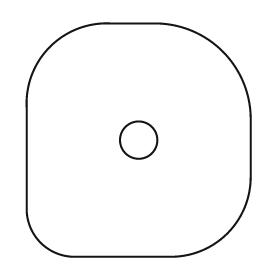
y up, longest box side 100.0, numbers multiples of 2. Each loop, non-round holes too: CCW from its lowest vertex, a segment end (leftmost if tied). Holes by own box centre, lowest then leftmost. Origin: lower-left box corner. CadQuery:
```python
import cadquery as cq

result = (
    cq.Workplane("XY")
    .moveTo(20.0, 0.0)
    .lineTo(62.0, 0.0)
    .threePointArc((86.0, 10.0), (96.0, 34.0))
    .lineTo(96.0, 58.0)
    .threePointArc((84.0, 88.0), (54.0, 100.0))
    .lineTo(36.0, 100.0)
    .threePointArc((10.0, 90.0), (0.0, 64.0))
    .lineTo(0.0, 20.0)
    .threePointArc((6.0, 6.0), (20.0, 0.0))
    .close()
    .moveTo(48.0, 50.0)
    .circle(8.0)
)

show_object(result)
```